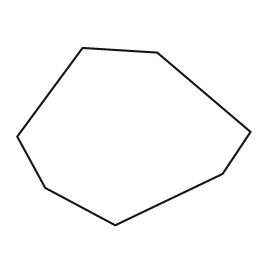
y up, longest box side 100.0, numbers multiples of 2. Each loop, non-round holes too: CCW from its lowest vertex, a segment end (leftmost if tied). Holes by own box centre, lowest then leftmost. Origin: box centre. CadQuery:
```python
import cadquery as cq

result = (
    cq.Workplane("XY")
    .moveTo(-8.0, -38.0)
    .lineTo(38.0, -16.0)
    .lineTo(50.0, 2.0)
    .lineTo(10.0, 36.0)
    .lineTo(-22.0, 38.0)
    .lineTo(-50.0, 0.0)
    .lineTo(-38.0, -22.0)
    .close()
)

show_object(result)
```